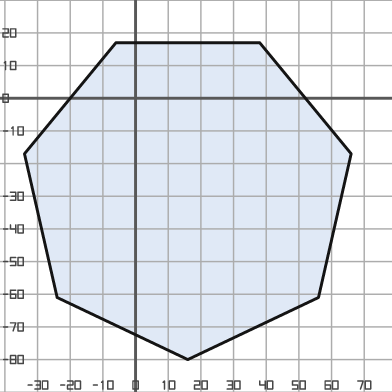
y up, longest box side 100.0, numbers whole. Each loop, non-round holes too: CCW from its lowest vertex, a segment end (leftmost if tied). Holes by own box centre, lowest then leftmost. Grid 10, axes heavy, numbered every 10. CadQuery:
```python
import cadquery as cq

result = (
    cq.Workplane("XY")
    .moveTo(16.0, -80.0)
    .lineTo(56.0, -61.0)
    .lineTo(66.0, -17.0)
    .lineTo(38.0, 17.0)
    .lineTo(-6.0, 17.0)
    .lineTo(-34.0, -17.0)
    .lineTo(-24.0, -61.0)
    .close()
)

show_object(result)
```